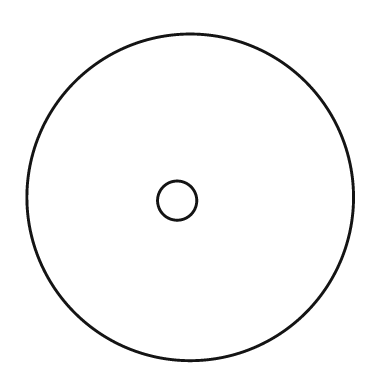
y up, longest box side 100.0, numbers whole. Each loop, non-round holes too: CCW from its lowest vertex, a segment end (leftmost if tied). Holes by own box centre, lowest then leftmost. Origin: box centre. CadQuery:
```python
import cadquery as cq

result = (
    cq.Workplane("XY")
    .moveTo(0.0, 0.0)
    .circle(50.0)
    .moveTo(-4.0, -1.0)
    .circle(6.0)
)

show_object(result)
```